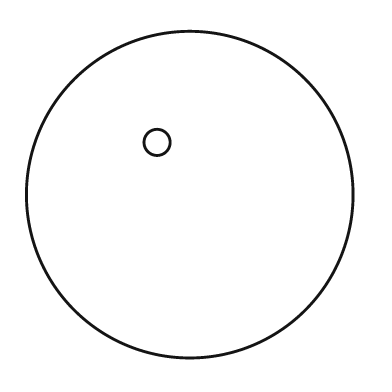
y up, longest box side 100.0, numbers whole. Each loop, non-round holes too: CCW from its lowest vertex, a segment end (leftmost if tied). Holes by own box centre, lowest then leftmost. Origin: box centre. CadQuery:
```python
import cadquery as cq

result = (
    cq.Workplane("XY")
    .moveTo(0.0, 0.0)
    .circle(50.0)
    .moveTo(-10.0, 16.0)
    .circle(4.0)
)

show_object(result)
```